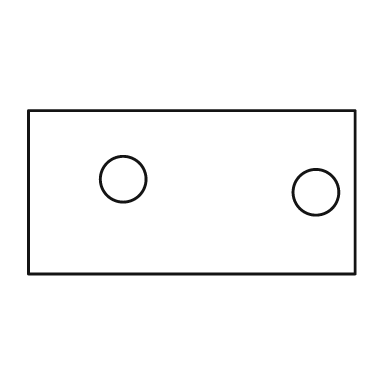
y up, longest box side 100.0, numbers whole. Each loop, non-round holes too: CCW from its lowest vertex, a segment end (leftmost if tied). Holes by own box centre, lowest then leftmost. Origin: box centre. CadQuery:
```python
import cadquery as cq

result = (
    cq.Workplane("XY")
    .moveTo(-50.0, -25.0)
    .lineTo(50.0, -25.0)
    .lineTo(50.0, 25.0)
    .lineTo(-50.0, 25.0)
    .close()
    .moveTo(38.0, 0.0)
    .circle(7.0)
    .moveTo(-21.0, 4.0)
    .circle(7.0)
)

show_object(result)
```